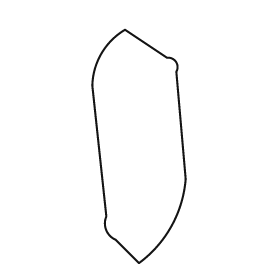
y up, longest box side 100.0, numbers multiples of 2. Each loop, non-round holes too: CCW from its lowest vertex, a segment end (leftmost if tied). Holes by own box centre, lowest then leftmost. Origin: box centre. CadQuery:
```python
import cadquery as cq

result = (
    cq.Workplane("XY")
    .moveTo(0.0, -50.0)
    .threePointArc((14.0, -34.0), (20.0, -14.0))
    .lineTo(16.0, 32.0)
    .threePointArc((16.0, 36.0), (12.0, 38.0))
    .lineTo(-6.0, 50.0)
    .threePointArc((-16.0, 40.0), (-20.0, 26.0))
    .lineTo(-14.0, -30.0)
    .threePointArc((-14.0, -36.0), (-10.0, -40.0))
    .close()
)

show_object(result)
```